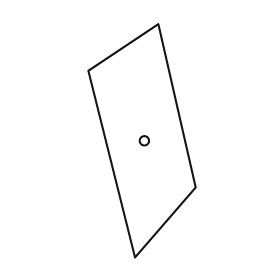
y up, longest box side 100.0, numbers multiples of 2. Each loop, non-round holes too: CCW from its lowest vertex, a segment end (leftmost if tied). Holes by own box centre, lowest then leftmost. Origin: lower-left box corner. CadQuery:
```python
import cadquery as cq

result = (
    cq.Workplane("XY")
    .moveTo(20.0, 0.0)
    .lineTo(46.0, 30.0)
    .lineTo(30.0, 100.0)
    .lineTo(0.0, 80.0)
    .close()
    .moveTo(24.0, 50.0)
    .circle(2.0)
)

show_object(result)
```